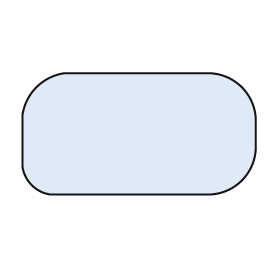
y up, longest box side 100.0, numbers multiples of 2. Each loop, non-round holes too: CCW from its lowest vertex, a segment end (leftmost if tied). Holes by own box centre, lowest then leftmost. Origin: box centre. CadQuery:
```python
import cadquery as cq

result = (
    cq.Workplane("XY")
    .moveTo(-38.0, -26.0)
    .lineTo(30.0, -26.0)
    .threePointArc((44.0, -20.0), (50.0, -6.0))
    .lineTo(50.0, 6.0)
    .threePointArc((44.0, 20.0), (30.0, 26.0))
    .lineTo(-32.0, 26.0)
    .threePointArc((-44.0, 20.0), (-50.0, 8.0))
    .lineTo(-50.0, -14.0)
    .threePointArc((-46.0, -22.0), (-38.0, -26.0))
    .close()
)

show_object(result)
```